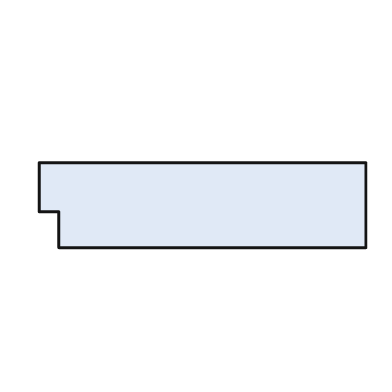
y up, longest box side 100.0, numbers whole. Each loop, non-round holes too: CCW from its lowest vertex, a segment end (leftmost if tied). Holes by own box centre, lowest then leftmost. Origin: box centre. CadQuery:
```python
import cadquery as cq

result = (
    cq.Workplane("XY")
    .moveTo(-44.0, -13.0)
    .lineTo(50.0, -13.0)
    .lineTo(50.0, 13.0)
    .lineTo(-50.0, 13.0)
    .lineTo(-50.0, -2.0)
    .lineTo(-44.0, -2.0)
    .close()
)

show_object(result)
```